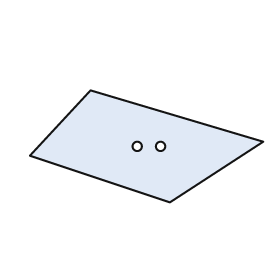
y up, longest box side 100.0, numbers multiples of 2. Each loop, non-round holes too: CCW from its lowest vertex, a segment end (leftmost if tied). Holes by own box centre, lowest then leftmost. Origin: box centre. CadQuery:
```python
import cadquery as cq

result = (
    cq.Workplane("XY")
    .moveTo(10.0, -24.0)
    .lineTo(50.0, 2.0)
    .lineTo(-24.0, 24.0)
    .lineTo(-50.0, -4.0)
    .close()
    .moveTo(-4.0, 0.0)
    .circle(2.0)
    .moveTo(6.0, 0.0)
    .circle(2.0)
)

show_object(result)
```